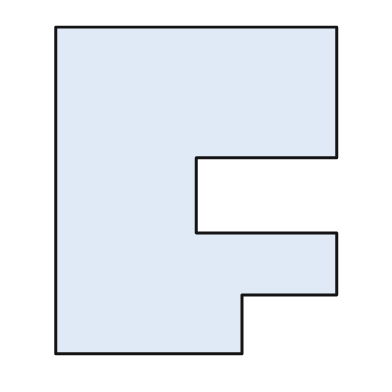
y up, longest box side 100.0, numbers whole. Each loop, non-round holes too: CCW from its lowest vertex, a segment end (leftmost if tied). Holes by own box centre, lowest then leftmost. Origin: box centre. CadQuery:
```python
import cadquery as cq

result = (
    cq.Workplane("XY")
    .moveTo(-43.0, -50.0)
    .lineTo(14.0, -50.0)
    .lineTo(14.0, -32.0)
    .lineTo(43.0, -32.0)
    .lineTo(43.0, -13.0)
    .lineTo(0.0, -13.0)
    .lineTo(0.0, 10.0)
    .lineTo(43.0, 10.0)
    .lineTo(43.0, 50.0)
    .lineTo(-43.0, 50.0)
    .close()
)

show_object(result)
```